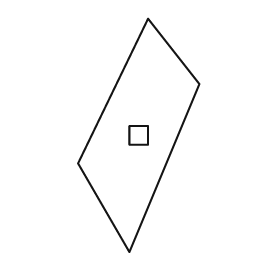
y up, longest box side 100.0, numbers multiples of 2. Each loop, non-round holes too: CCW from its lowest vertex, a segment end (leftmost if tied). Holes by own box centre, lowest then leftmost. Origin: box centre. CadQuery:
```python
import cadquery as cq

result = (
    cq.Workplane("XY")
    .moveTo(-4.0, -50.0)
    .lineTo(26.0, 22.0)
    .lineTo(4.0, 50.0)
    .lineTo(-26.0, -12.0)
    .close()
    .moveTo(-4.0, -4.0)
    .lineTo(4.0, -4.0)
    .lineTo(4.0, 4.0)
    .lineTo(-4.0, 4.0)
    .close()
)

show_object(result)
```